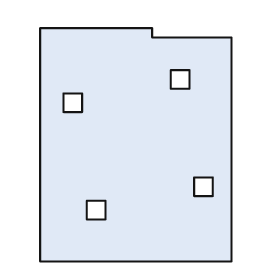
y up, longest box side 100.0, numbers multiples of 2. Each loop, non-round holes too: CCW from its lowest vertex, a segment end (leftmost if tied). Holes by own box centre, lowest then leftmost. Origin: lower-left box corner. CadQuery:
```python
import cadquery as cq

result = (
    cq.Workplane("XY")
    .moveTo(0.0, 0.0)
    .lineTo(82.0, 0.0)
    .lineTo(82.0, 96.0)
    .lineTo(48.0, 96.0)
    .lineTo(48.0, 100.0)
    .lineTo(0.0, 100.0)
    .close()
    .moveTo(20.0, 18.0)
    .lineTo(28.0, 18.0)
    .lineTo(28.0, 26.0)
    .lineTo(20.0, 26.0)
    .close()
    .moveTo(66.0, 28.0)
    .lineTo(74.0, 28.0)
    .lineTo(74.0, 36.0)
    .lineTo(66.0, 36.0)
    .close()
    .moveTo(10.0, 64.0)
    .lineTo(18.0, 64.0)
    .lineTo(18.0, 72.0)
    .lineTo(10.0, 72.0)
    .close()
    .moveTo(56.0, 74.0)
    .lineTo(64.0, 74.0)
    .lineTo(64.0, 82.0)
    .lineTo(56.0, 82.0)
    .close()
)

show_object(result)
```